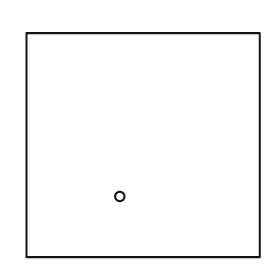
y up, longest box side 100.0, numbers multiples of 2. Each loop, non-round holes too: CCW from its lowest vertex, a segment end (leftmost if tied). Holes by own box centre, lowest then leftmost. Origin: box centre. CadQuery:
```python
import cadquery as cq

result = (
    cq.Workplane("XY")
    .moveTo(-50.0, -48.0)
    .lineTo(50.0, -48.0)
    .lineTo(50.0, 48.0)
    .lineTo(-50.0, 48.0)
    .close()
    .moveTo(-10.0, -22.0)
    .circle(2.0)
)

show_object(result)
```